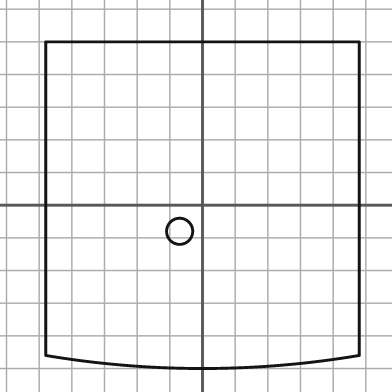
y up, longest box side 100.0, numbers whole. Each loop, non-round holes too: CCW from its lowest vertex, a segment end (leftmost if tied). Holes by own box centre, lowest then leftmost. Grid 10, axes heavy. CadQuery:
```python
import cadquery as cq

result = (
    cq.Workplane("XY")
    .moveTo(-48.0, -46.0)
    .threePointArc((0.0, -50.0), (48.0, -46.0))
    .lineTo(48.0, 50.0)
    .lineTo(-48.0, 50.0)
    .close()
    .moveTo(-7.0, -8.0)
    .circle(4.0)
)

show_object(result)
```